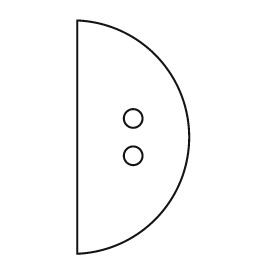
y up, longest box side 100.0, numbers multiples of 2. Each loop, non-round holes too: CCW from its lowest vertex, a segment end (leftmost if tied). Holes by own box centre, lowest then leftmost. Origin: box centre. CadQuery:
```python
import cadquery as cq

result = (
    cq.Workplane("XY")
    .moveTo(-24.0, -50.0)
    .threePointArc((24.0, 0.0), (-24.0, 50.0))
    .close()
    .moveTo(0.0, -8.0)
    .circle(4.0)
    .moveTo(0.0, 8.0)
    .circle(4.0)
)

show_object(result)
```